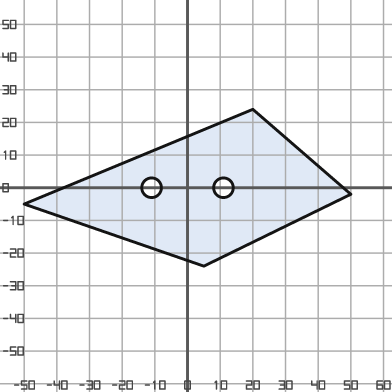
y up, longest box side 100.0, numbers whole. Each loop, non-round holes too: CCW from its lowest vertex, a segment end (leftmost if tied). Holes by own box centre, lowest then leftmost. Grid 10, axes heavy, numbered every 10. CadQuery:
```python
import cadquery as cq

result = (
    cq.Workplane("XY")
    .moveTo(5.0, -24.0)
    .lineTo(50.0, -2.0)
    .lineTo(20.0, 24.0)
    .lineTo(-50.0, -5.0)
    .close()
    .moveTo(-11.0, 0.0)
    .circle(3.0)
    .moveTo(11.0, 0.0)
    .circle(3.0)
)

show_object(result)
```